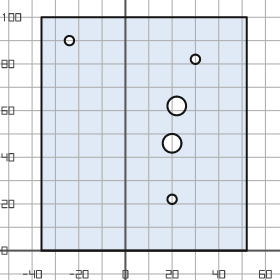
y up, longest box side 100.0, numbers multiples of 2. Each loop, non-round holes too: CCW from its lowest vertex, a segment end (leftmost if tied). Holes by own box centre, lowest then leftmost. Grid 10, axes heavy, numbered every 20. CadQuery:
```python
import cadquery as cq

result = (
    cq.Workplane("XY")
    .moveTo(-36.0, 0.0)
    .lineTo(52.0, 0.0)
    .lineTo(52.0, 100.0)
    .lineTo(-36.0, 100.0)
    .close()
    .moveTo(20.0, 22.0)
    .circle(2.0)
    .moveTo(20.0, 46.0)
    .circle(4.0)
    .moveTo(22.0, 62.0)
    .circle(4.0)
    .moveTo(30.0, 82.0)
    .circle(2.0)
    .moveTo(-24.0, 90.0)
    .circle(2.0)
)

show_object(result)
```